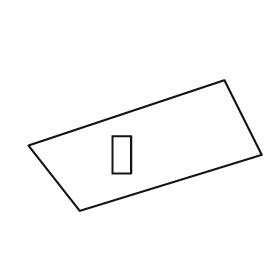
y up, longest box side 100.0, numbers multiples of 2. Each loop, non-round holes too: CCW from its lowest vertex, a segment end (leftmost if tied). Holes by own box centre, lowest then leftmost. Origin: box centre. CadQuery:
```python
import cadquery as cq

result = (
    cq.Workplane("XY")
    .moveTo(-28.0, -28.0)
    .lineTo(50.0, -4.0)
    .lineTo(34.0, 28.0)
    .lineTo(-50.0, 0.0)
    .close()
    .moveTo(-14.0, -12.0)
    .lineTo(-6.0, -12.0)
    .lineTo(-6.0, 4.0)
    .lineTo(-14.0, 4.0)
    .close()
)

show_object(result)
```